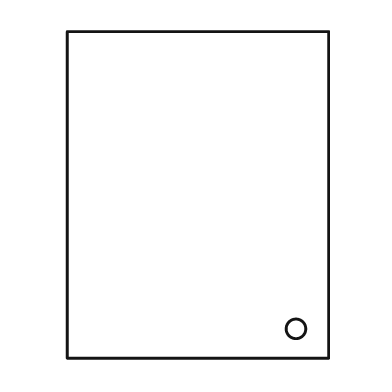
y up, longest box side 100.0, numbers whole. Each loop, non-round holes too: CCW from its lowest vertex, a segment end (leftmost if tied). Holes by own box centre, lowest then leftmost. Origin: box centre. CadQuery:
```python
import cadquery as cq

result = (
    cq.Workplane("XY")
    .moveTo(-40.0, -50.0)
    .lineTo(40.0, -50.0)
    .lineTo(40.0, 50.0)
    .lineTo(-40.0, 50.0)
    .close()
    .moveTo(30.0, -41.0)
    .circle(3.0)
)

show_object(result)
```